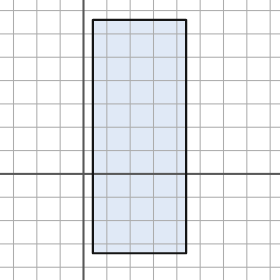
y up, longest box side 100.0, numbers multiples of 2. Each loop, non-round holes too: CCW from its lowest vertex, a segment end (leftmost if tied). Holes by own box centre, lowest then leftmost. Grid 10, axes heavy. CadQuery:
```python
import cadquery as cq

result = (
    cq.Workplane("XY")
    .moveTo(4.0, -34.0)
    .lineTo(44.0, -34.0)
    .lineTo(44.0, 66.0)
    .lineTo(4.0, 66.0)
    .close()
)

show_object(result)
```